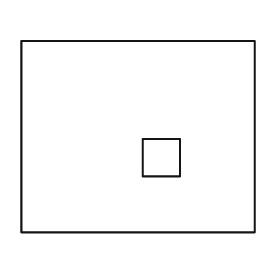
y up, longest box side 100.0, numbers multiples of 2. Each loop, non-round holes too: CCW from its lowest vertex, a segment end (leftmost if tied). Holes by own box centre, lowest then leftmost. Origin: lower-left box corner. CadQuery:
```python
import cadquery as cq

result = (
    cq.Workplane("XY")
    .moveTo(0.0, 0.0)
    .lineTo(100.0, 0.0)
    .lineTo(100.0, 82.0)
    .lineTo(0.0, 82.0)
    .close()
    .moveTo(52.0, 24.0)
    .lineTo(68.0, 24.0)
    .lineTo(68.0, 40.0)
    .lineTo(52.0, 40.0)
    .close()
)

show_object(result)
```